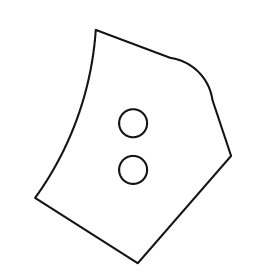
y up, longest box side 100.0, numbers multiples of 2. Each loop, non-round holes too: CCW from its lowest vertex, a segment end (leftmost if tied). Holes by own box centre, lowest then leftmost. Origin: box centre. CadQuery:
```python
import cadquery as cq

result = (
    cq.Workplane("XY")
    .moveTo(2.0, -50.0)
    .lineTo(42.0, -4.0)
    .lineTo(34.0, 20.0)
    .threePointArc((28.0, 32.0), (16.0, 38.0))
    .lineTo(-16.0, 50.0)
    .threePointArc((-24.0, 12.0), (-42.0, -22.0))
    .close()
    .moveTo(0.0, -10.0)
    .circle(6.0)
    .moveTo(0.0, 10.0)
    .circle(6.0)
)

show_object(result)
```